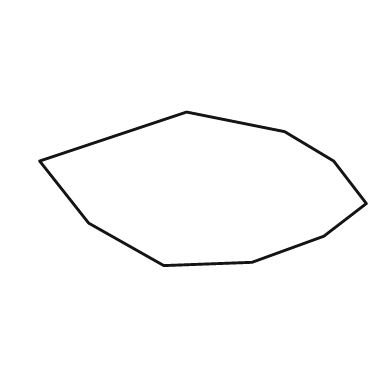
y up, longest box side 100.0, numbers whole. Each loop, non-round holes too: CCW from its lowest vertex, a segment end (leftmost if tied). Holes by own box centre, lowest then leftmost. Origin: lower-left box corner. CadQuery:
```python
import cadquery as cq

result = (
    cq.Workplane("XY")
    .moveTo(38.0, 0.0)
    .lineTo(65.0, 1.0)
    .lineTo(87.0, 9.0)
    .lineTo(100.0, 19.0)
    .lineTo(90.0, 32.0)
    .lineTo(75.0, 41.0)
    .lineTo(45.0, 47.0)
    .lineTo(0.0, 32.0)
    .lineTo(15.0, 13.0)
    .close()
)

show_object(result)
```